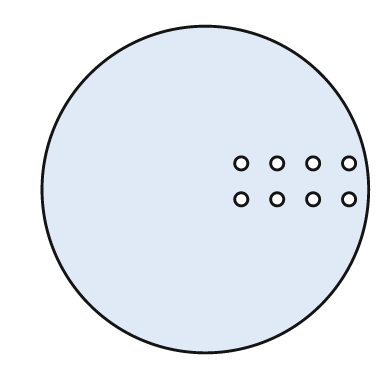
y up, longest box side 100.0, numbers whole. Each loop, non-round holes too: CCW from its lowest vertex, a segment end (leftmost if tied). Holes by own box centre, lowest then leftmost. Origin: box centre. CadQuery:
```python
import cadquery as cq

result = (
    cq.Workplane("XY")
    .moveTo(0.0, 0.0)
    .circle(50.0)
    .moveTo(11.0, -3.0)
    .circle(2.0)
    .moveTo(22.0, -3.0)
    .circle(2.0)
    .moveTo(33.0, -3.0)
    .circle(2.0)
    .moveTo(44.0, -3.0)
    .circle(2.0)
    .moveTo(11.0, 8.0)
    .circle(2.0)
    .moveTo(22.0, 8.0)
    .circle(2.0)
    .moveTo(33.0, 8.0)
    .circle(2.0)
    .moveTo(44.0, 8.0)
    .circle(2.0)
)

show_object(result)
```